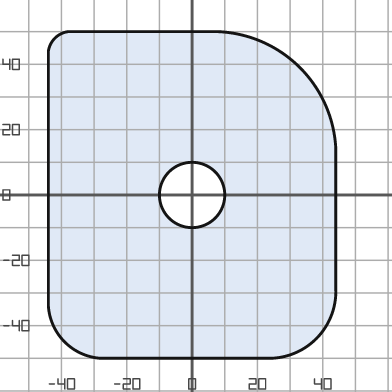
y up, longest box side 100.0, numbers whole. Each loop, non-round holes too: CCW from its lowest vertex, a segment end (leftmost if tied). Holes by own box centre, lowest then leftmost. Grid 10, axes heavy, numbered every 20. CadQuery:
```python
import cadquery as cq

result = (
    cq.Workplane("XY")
    .moveTo(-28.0, -50.0)
    .lineTo(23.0, -50.0)
    .threePointArc((38.0, -44.0), (44.0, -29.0))
    .lineTo(44.0, 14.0)
    .threePointArc((33.0, 39.0), (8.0, 50.0))
    .lineTo(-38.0, 50.0)
    .threePointArc((-42.0, 48.0), (-44.0, 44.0))
    .lineTo(-44.0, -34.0)
    .threePointArc((-39.0, -45.0), (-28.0, -50.0))
    .close()
    .moveTo(0.0, 0.0)
    .circle(10.0)
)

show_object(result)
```